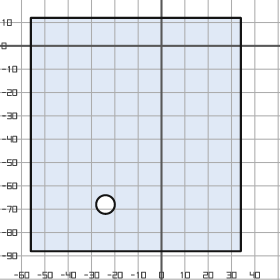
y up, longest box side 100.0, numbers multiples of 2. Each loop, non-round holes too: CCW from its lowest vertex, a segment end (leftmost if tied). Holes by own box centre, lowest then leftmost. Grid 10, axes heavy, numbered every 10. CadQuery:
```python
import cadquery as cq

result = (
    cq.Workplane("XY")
    .moveTo(-56.0, -88.0)
    .lineTo(34.0, -88.0)
    .lineTo(34.0, 12.0)
    .lineTo(-56.0, 12.0)
    .close()
    .moveTo(-24.0, -68.0)
    .circle(4.0)
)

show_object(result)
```